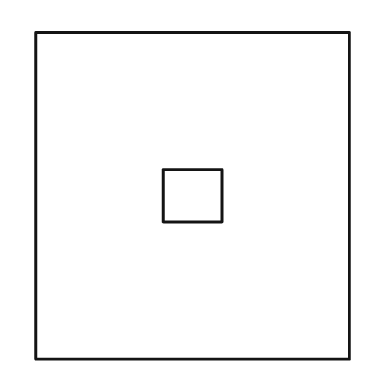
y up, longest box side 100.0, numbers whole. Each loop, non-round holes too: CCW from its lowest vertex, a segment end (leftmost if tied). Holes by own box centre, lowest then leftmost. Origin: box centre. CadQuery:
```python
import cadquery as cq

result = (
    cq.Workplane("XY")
    .moveTo(-48.0, -50.0)
    .lineTo(48.0, -50.0)
    .lineTo(48.0, 50.0)
    .lineTo(-48.0, 50.0)
    .close()
    .moveTo(-9.0, -8.0)
    .lineTo(9.0, -8.0)
    .lineTo(9.0, 8.0)
    .lineTo(-9.0, 8.0)
    .close()
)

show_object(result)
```